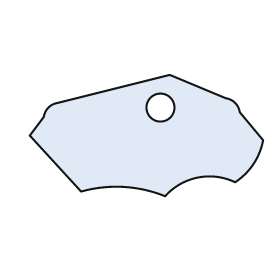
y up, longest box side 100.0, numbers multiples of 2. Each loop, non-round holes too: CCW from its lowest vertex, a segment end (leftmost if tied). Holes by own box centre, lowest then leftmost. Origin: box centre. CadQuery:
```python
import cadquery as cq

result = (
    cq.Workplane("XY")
    .moveTo(8.0, -26.0)
    .threePointArc((22.0, -18.0), (38.0, -20.0))
    .threePointArc((46.0, -12.0), (50.0, -2.0))
    .lineTo(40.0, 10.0)
    .threePointArc((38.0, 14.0), (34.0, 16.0))
    .lineTo(10.0, 26.0)
    .lineTo(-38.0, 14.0)
    .threePointArc((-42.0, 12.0), (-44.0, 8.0))
    .lineTo(-50.0, 0.0)
    .lineTo(-28.0, -24.0)
    .threePointArc((-10.0, -22.0), (8.0, -26.0))
    .close()
    .moveTo(6.0, 12.0)
    .circle(6.0)
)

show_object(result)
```